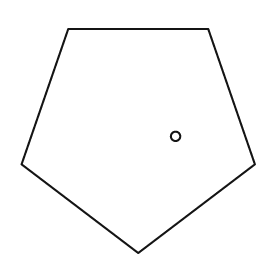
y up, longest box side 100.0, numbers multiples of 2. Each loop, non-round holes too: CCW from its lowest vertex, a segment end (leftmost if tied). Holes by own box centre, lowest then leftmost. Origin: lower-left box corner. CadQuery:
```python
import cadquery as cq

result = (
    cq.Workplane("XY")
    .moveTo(50.0, 0.0)
    .lineTo(100.0, 38.0)
    .lineTo(80.0, 96.0)
    .lineTo(20.0, 96.0)
    .lineTo(0.0, 38.0)
    .close()
    .moveTo(66.0, 50.0)
    .circle(2.0)
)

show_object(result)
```